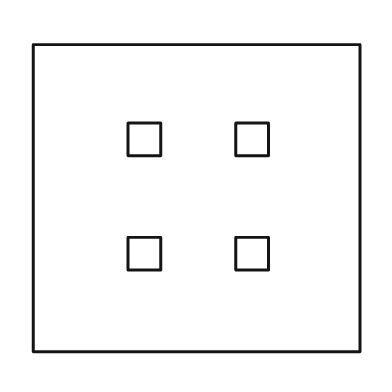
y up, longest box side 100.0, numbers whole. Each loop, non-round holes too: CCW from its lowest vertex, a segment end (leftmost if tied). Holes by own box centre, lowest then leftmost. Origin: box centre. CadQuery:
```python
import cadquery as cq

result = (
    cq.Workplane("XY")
    .moveTo(-50.0, -47.0)
    .lineTo(50.0, -47.0)
    .lineTo(50.0, 47.0)
    .lineTo(-50.0, 47.0)
    .close()
    .moveTo(-21.0, -22.0)
    .lineTo(-11.0, -22.0)
    .lineTo(-11.0, -12.0)
    .lineTo(-21.0, -12.0)
    .close()
    .moveTo(12.0, -22.0)
    .lineTo(22.0, -22.0)
    .lineTo(22.0, -12.0)
    .lineTo(12.0, -12.0)
    .close()
    .moveTo(-21.0, 13.0)
    .lineTo(-11.0, 13.0)
    .lineTo(-11.0, 23.0)
    .lineTo(-21.0, 23.0)
    .close()
    .moveTo(12.0, 13.0)
    .lineTo(22.0, 13.0)
    .lineTo(22.0, 23.0)
    .lineTo(12.0, 23.0)
    .close()
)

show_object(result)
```